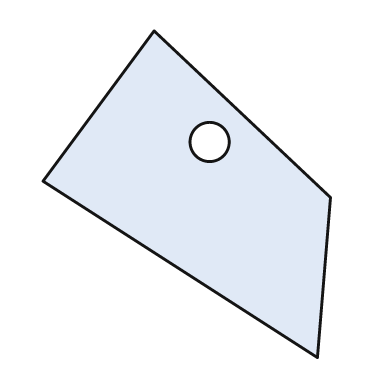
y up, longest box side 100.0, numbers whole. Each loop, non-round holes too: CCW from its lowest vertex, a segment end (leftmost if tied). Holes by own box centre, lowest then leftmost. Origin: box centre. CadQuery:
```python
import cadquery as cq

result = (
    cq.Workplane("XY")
    .moveTo(40.0, -50.0)
    .lineTo(44.0, -1.0)
    .lineTo(-10.0, 50.0)
    .lineTo(-44.0, 4.0)
    .close()
    .moveTo(7.0, 16.0)
    .circle(6.0)
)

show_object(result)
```